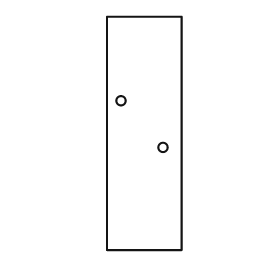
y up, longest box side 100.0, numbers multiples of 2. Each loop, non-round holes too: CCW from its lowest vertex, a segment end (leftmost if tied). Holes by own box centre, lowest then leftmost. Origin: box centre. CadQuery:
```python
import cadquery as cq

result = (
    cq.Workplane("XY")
    .moveTo(-16.0, -50.0)
    .lineTo(16.0, -50.0)
    .lineTo(16.0, 50.0)
    .lineTo(-16.0, 50.0)
    .close()
    .moveTo(8.0, -6.0)
    .circle(2.0)
    .moveTo(-10.0, 14.0)
    .circle(2.0)
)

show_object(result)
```